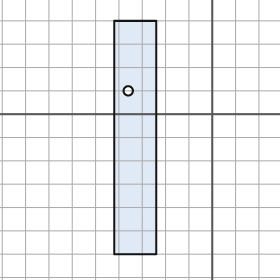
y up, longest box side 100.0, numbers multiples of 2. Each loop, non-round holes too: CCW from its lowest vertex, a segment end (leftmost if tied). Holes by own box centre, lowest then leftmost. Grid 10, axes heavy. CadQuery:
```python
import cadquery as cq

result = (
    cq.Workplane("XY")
    .moveTo(-42.0, -60.0)
    .lineTo(-24.0, -60.0)
    .lineTo(-24.0, 40.0)
    .lineTo(-42.0, 40.0)
    .close()
    .moveTo(-36.0, 10.0)
    .circle(2.0)
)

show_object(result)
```